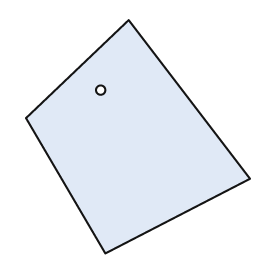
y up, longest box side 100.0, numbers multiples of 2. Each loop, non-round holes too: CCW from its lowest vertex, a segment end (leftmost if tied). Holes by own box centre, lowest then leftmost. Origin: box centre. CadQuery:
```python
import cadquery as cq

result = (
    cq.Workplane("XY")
    .moveTo(-14.0, -50.0)
    .lineTo(48.0, -18.0)
    .lineTo(-4.0, 50.0)
    .lineTo(-48.0, 8.0)
    .close()
    .moveTo(-16.0, 20.0)
    .circle(2.0)
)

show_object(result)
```